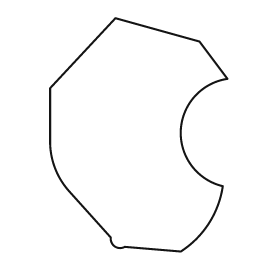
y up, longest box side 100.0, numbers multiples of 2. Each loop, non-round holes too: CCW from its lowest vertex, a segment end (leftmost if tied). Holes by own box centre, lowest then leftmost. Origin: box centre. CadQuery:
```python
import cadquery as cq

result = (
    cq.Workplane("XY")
    .moveTo(18.0, -50.0)
    .threePointArc((30.0, -38.0), (36.0, -22.0))
    .threePointArc((18.0, 2.0), (38.0, 24.0))
    .lineTo(26.0, 40.0)
    .lineTo(-10.0, 50.0)
    .lineTo(-38.0, 20.0)
    .lineTo(-38.0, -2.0)
    .threePointArc((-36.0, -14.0), (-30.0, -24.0))
    .lineTo(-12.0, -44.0)
    .threePointArc((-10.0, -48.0), (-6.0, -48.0))
    .close()
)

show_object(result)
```